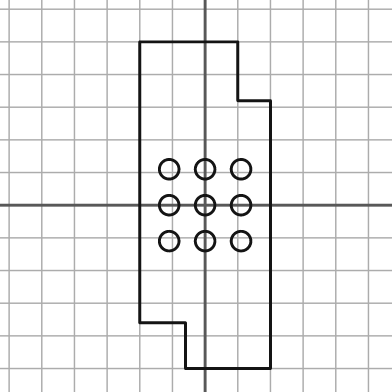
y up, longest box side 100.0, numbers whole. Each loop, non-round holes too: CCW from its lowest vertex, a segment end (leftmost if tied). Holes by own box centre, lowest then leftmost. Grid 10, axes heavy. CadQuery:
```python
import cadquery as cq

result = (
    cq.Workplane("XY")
    .moveTo(-6.0, -50.0)
    .lineTo(20.0, -50.0)
    .lineTo(20.0, 32.0)
    .lineTo(10.0, 32.0)
    .lineTo(10.0, 50.0)
    .lineTo(-20.0, 50.0)
    .lineTo(-20.0, -36.0)
    .lineTo(-6.0, -36.0)
    .close()
    .moveTo(-11.0, -11.0)
    .circle(3.0)
    .moveTo(0.0, -11.0)
    .circle(3.0)
    .moveTo(11.0, -11.0)
    .circle(3.0)
    .moveTo(-11.0, 0.0)
    .circle(3.0)
    .moveTo(0.0, 0.0)
    .circle(3.0)
    .moveTo(11.0, 0.0)
    .circle(3.0)
    .moveTo(-11.0, 11.0)
    .circle(3.0)
    .moveTo(0.0, 11.0)
    .circle(3.0)
    .moveTo(11.0, 11.0)
    .circle(3.0)
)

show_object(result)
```